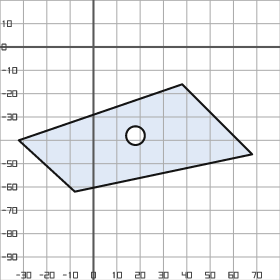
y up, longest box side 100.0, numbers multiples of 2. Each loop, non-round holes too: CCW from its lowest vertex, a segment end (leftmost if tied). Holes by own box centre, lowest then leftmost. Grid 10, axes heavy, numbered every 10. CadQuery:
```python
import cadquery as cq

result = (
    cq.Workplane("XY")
    .moveTo(-8.0, -62.0)
    .lineTo(68.0, -46.0)
    .lineTo(38.0, -16.0)
    .lineTo(-32.0, -40.0)
    .close()
    .moveTo(18.0, -38.0)
    .circle(4.0)
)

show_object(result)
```